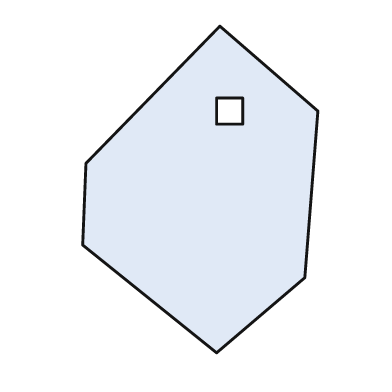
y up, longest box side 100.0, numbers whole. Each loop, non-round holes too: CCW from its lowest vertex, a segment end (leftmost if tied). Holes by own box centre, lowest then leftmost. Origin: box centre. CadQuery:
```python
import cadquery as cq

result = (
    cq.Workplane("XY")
    .moveTo(5.0, -50.0)
    .lineTo(32.0, -27.0)
    .lineTo(36.0, 24.0)
    .lineTo(6.0, 50.0)
    .lineTo(-35.0, 8.0)
    .lineTo(-36.0, -17.0)
    .close()
    .moveTo(5.0, 20.0)
    .lineTo(13.0, 20.0)
    .lineTo(13.0, 28.0)
    .lineTo(5.0, 28.0)
    .close()
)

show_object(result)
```